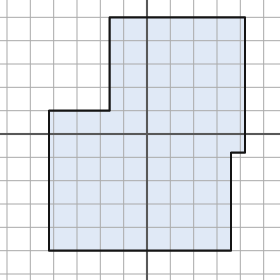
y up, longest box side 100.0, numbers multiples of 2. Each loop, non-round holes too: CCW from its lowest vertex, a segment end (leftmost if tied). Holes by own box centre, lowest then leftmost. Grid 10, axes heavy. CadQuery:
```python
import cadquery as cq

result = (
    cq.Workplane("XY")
    .moveTo(-42.0, -50.0)
    .lineTo(36.0, -50.0)
    .lineTo(36.0, -8.0)
    .lineTo(42.0, -8.0)
    .lineTo(42.0, 50.0)
    .lineTo(-16.0, 50.0)
    .lineTo(-16.0, 10.0)
    .lineTo(-42.0, 10.0)
    .close()
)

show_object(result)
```